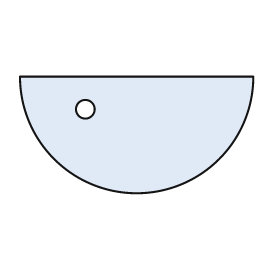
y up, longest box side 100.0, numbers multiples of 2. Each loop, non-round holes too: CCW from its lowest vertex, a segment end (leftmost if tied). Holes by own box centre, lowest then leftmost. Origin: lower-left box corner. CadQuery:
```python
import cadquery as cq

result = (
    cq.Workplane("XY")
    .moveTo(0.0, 50.0)
    .threePointArc((50.0, 0.0), (100.0, 50.0))
    .close()
    .moveTo(28.0, 36.0)
    .circle(4.0)
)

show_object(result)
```